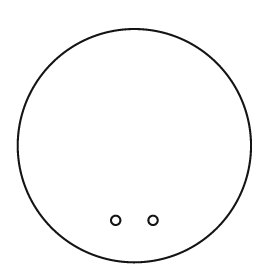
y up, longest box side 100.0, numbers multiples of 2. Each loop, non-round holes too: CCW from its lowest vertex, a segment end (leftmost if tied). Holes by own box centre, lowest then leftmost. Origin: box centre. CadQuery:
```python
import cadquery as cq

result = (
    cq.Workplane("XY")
    .moveTo(0.0, 0.0)
    .circle(50.0)
    .moveTo(-8.0, -32.0)
    .circle(2.0)
    .moveTo(8.0, -32.0)
    .circle(2.0)
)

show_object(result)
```